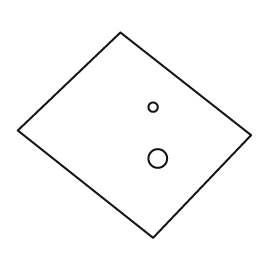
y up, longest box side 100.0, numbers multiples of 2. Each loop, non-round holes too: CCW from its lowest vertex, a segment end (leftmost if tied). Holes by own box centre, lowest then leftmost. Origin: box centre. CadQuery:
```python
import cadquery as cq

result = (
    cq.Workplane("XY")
    .moveTo(8.0, -44.0)
    .lineTo(50.0, 0.0)
    .lineTo(-6.0, 44.0)
    .lineTo(-50.0, 2.0)
    .close()
    .moveTo(10.0, -10.0)
    .circle(4.0)
    .moveTo(8.0, 12.0)
    .circle(2.0)
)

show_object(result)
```